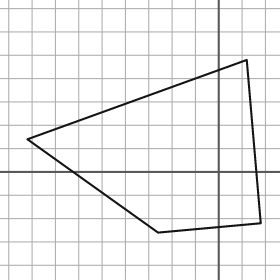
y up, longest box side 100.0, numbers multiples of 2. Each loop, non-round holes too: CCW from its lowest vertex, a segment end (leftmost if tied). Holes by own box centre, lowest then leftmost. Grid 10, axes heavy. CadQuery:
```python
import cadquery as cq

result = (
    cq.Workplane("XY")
    .moveTo(-26.0, -26.0)
    .lineTo(18.0, -22.0)
    .lineTo(12.0, 48.0)
    .lineTo(-82.0, 14.0)
    .close()
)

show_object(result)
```